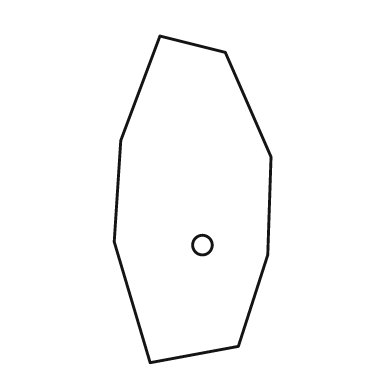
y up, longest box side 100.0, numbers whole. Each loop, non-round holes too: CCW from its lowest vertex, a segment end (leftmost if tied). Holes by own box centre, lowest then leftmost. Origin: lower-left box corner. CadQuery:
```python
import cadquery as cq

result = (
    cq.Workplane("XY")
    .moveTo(11.0, 0.0)
    .lineTo(38.0, 5.0)
    .lineTo(47.0, 33.0)
    .lineTo(48.0, 63.0)
    .lineTo(34.0, 95.0)
    .lineTo(14.0, 100.0)
    .lineTo(2.0, 68.0)
    .lineTo(0.0, 37.0)
    .close()
    .moveTo(27.0, 36.0)
    .circle(3.0)
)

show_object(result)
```